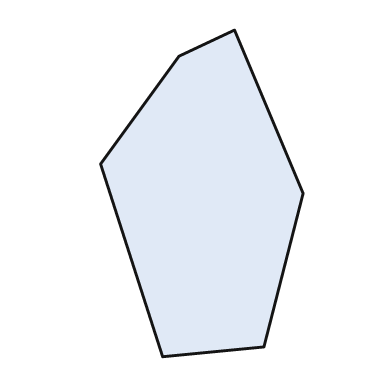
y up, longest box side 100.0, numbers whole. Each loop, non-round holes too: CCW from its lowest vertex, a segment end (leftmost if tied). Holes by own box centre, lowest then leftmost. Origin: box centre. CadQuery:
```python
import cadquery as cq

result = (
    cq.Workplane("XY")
    .moveTo(-12.0, -50.0)
    .lineTo(19.0, -47.0)
    .lineTo(31.0, 0.0)
    .lineTo(10.0, 50.0)
    .lineTo(-7.0, 42.0)
    .lineTo(-31.0, 9.0)
    .close()
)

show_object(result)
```